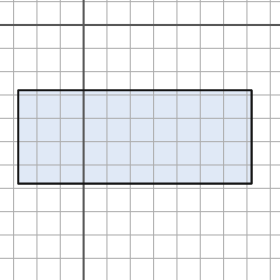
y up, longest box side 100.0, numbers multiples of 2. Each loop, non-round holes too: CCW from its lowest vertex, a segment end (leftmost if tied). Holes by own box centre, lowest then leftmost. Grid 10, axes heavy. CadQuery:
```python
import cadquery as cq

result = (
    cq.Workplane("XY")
    .moveTo(-28.0, -68.0)
    .lineTo(72.0, -68.0)
    .lineTo(72.0, -28.0)
    .lineTo(-28.0, -28.0)
    .close()
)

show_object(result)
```